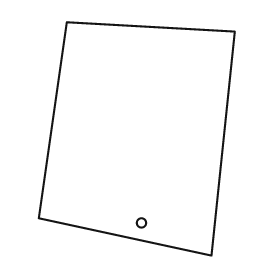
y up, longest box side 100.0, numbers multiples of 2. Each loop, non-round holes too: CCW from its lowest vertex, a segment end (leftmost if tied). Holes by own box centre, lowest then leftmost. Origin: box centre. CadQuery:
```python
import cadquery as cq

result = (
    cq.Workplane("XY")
    .moveTo(32.0, -50.0)
    .lineTo(42.0, 46.0)
    .lineTo(-30.0, 50.0)
    .lineTo(-42.0, -34.0)
    .close()
    .moveTo(2.0, -36.0)
    .circle(2.0)
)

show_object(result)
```